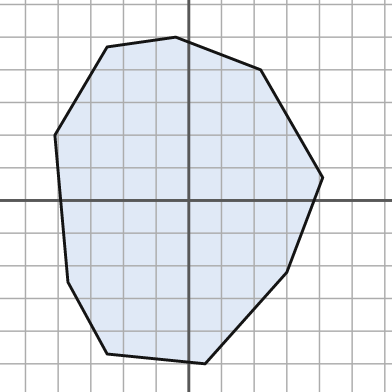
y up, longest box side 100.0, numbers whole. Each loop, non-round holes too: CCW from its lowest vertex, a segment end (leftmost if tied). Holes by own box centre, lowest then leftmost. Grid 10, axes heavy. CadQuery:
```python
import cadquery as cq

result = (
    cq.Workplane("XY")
    .moveTo(5.0, -50.0)
    .lineTo(30.0, -22.0)
    .lineTo(41.0, 7.0)
    .lineTo(22.0, 40.0)
    .lineTo(-4.0, 50.0)
    .lineTo(-25.0, 47.0)
    .lineTo(-41.0, 20.0)
    .lineTo(-37.0, -25.0)
    .lineTo(-25.0, -47.0)
    .close()
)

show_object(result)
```